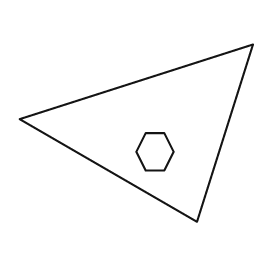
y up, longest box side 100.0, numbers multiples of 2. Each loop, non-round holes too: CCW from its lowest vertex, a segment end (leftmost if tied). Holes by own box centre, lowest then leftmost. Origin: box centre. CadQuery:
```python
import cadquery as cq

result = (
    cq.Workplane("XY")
    .moveTo(26.0, -38.0)
    .lineTo(50.0, 38.0)
    .lineTo(-50.0, 6.0)
    .close()
    .moveTo(4.0, -16.0)
    .lineTo(12.0, -16.0)
    .lineTo(16.0, -8.0)
    .lineTo(12.0, 0.0)
    .lineTo(4.0, 0.0)
    .lineTo(0.0, -8.0)
    .close()
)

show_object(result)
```